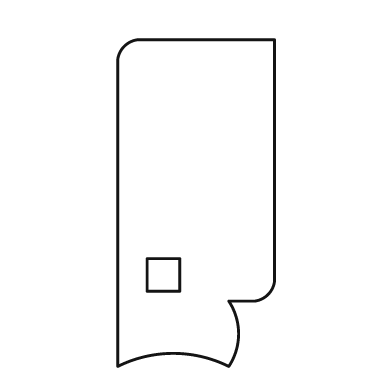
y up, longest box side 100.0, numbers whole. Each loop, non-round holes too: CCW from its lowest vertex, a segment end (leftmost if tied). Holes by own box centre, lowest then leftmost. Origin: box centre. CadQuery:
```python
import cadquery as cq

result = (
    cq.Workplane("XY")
    .moveTo(-24.0, -50.0)
    .threePointArc((-7.0, -46.0), (10.0, -50.0))
    .threePointArc((13.0, -40.0), (10.0, -30.0))
    .lineTo(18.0, -30.0)
    .threePointArc((22.0, -28.0), (24.0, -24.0))
    .lineTo(24.0, 50.0)
    .lineTo(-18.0, 50.0)
    .threePointArc((-22.0, 48.0), (-24.0, 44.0))
    .close()
    .moveTo(-15.0, -27.0)
    .lineTo(-5.0, -27.0)
    .lineTo(-5.0, -17.0)
    .lineTo(-15.0, -17.0)
    .close()
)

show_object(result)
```